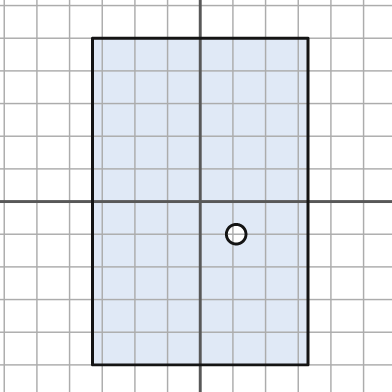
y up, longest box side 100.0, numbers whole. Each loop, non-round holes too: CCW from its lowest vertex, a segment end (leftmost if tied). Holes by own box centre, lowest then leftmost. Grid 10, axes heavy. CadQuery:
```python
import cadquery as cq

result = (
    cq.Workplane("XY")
    .moveTo(-33.0, -50.0)
    .lineTo(33.0, -50.0)
    .lineTo(33.0, 50.0)
    .lineTo(-33.0, 50.0)
    .close()
    .moveTo(11.0, -10.0)
    .circle(3.0)
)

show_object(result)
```